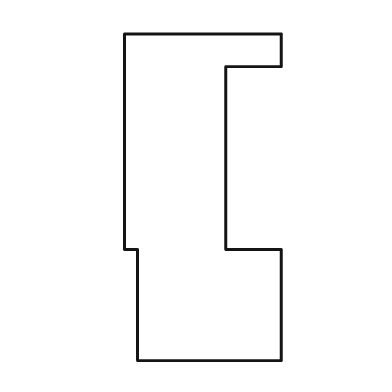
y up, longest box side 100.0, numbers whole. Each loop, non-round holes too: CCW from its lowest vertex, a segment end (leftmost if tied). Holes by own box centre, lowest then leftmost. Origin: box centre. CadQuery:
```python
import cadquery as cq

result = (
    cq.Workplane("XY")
    .moveTo(-20.0, -50.0)
    .lineTo(24.0, -50.0)
    .lineTo(24.0, -16.0)
    .lineTo(7.0, -16.0)
    .lineTo(7.0, 40.0)
    .lineTo(24.0, 40.0)
    .lineTo(24.0, 50.0)
    .lineTo(-24.0, 50.0)
    .lineTo(-24.0, -16.0)
    .lineTo(-20.0, -16.0)
    .close()
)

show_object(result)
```